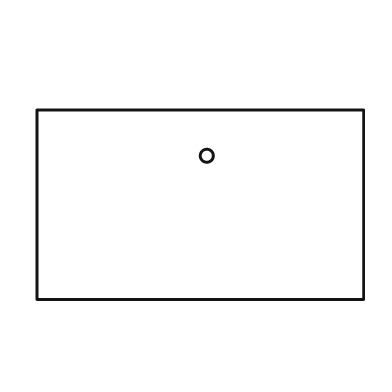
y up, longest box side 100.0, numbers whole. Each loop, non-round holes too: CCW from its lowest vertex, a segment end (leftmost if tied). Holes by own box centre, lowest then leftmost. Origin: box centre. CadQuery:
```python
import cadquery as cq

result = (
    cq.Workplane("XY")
    .moveTo(-50.0, -29.0)
    .lineTo(50.0, -29.0)
    .lineTo(50.0, 29.0)
    .lineTo(-50.0, 29.0)
    .close()
    .moveTo(2.0, 15.0)
    .circle(2.0)
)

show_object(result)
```